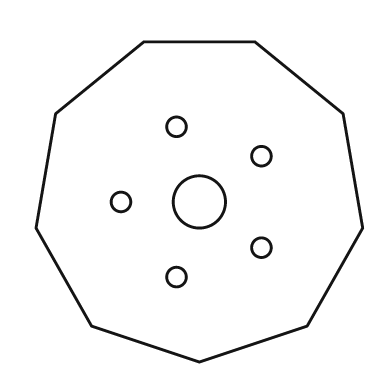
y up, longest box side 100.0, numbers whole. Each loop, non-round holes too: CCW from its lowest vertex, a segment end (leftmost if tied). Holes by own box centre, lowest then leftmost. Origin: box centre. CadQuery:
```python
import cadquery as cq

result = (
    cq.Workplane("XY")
    .moveTo(0.0, -49.0)
    .lineTo(33.0, -38.0)
    .lineTo(50.0, -8.0)
    .lineTo(44.0, 27.0)
    .lineTo(17.0, 49.0)
    .lineTo(-17.0, 49.0)
    .lineTo(-44.0, 27.0)
    .lineTo(-50.0, -8.0)
    .lineTo(-33.0, -38.0)
    .close()
    .moveTo(-7.0, -23.0)
    .circle(3.0)
    .moveTo(19.0, -14.0)
    .circle(3.0)
    .moveTo(-24.0, 0.0)
    .circle(3.0)
    .moveTo(0.0, 0.0)
    .circle(8.0)
    .moveTo(19.0, 14.0)
    .circle(3.0)
    .moveTo(-7.0, 23.0)
    .circle(3.0)
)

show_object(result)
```